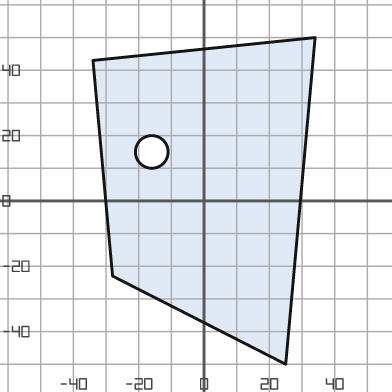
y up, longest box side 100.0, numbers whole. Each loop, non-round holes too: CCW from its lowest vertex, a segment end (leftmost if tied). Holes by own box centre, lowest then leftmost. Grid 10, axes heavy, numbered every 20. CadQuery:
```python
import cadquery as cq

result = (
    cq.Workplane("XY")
    .moveTo(25.0, -50.0)
    .lineTo(34.0, 50.0)
    .lineTo(-34.0, 43.0)
    .lineTo(-28.0, -23.0)
    .close()
    .moveTo(-16.0, 15.0)
    .circle(5.0)
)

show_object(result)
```